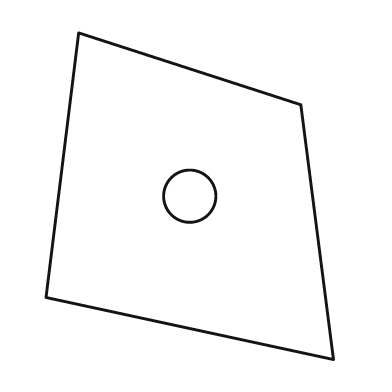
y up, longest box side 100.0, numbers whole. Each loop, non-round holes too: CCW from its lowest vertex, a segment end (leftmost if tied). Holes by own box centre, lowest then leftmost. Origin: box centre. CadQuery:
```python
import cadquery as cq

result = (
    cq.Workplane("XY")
    .moveTo(44.0, -50.0)
    .lineTo(34.0, 28.0)
    .lineTo(-34.0, 50.0)
    .lineTo(-44.0, -31.0)
    .close()
    .moveTo(0.0, 0.0)
    .circle(8.0)
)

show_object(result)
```